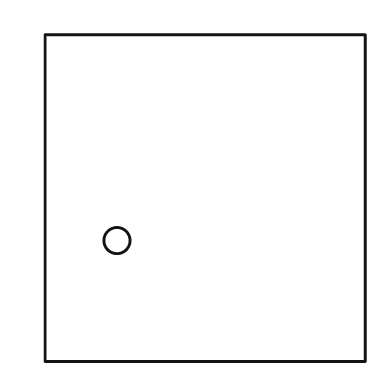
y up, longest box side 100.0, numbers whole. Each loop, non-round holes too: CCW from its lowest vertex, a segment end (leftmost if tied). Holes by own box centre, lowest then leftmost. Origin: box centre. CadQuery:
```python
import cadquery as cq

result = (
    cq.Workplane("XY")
    .moveTo(-49.0, -50.0)
    .lineTo(49.0, -50.0)
    .lineTo(49.0, 50.0)
    .lineTo(-49.0, 50.0)
    .close()
    .moveTo(-27.0, -13.0)
    .circle(4.0)
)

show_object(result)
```